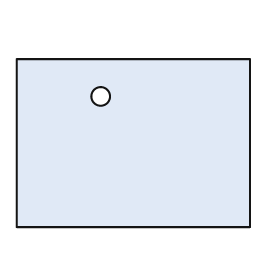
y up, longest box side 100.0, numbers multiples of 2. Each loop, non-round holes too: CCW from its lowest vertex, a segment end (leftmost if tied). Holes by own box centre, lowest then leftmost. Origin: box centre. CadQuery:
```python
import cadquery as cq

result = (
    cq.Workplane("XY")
    .moveTo(-50.0, -36.0)
    .lineTo(50.0, -36.0)
    .lineTo(50.0, 36.0)
    .lineTo(-50.0, 36.0)
    .close()
    .moveTo(-14.0, 20.0)
    .circle(4.0)
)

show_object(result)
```